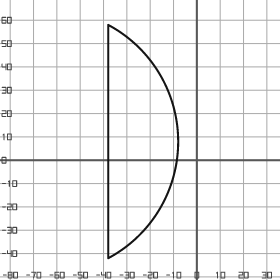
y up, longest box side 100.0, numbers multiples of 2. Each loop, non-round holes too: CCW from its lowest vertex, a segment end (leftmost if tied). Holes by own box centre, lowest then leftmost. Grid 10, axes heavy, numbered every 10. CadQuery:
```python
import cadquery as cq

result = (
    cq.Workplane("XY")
    .moveTo(-38.0, -42.0)
    .threePointArc((-8.0, 8.0), (-38.0, 58.0))
    .close()
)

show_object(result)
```